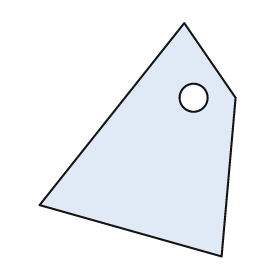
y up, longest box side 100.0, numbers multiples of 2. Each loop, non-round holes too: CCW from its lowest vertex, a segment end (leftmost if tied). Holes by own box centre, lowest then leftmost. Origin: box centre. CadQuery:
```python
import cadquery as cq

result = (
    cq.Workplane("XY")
    .moveTo(36.0, -50.0)
    .lineTo(42.0, 18.0)
    .lineTo(20.0, 50.0)
    .lineTo(-42.0, -28.0)
    .close()
    .moveTo(24.0, 18.0)
    .circle(6.0)
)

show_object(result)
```